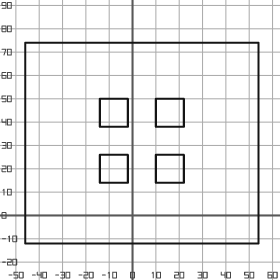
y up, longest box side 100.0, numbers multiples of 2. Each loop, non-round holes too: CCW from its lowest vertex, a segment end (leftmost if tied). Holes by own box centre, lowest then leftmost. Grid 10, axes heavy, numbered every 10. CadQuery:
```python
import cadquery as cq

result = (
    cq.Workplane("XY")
    .moveTo(-46.0, -12.0)
    .lineTo(54.0, -12.0)
    .lineTo(54.0, 74.0)
    .lineTo(-46.0, 74.0)
    .close()
    .moveTo(-14.0, 14.0)
    .lineTo(-2.0, 14.0)
    .lineTo(-2.0, 26.0)
    .lineTo(-14.0, 26.0)
    .close()
    .moveTo(10.0, 14.0)
    .lineTo(22.0, 14.0)
    .lineTo(22.0, 26.0)
    .lineTo(10.0, 26.0)
    .close()
    .moveTo(-14.0, 38.0)
    .lineTo(-2.0, 38.0)
    .lineTo(-2.0, 50.0)
    .lineTo(-14.0, 50.0)
    .close()
    .moveTo(10.0, 38.0)
    .lineTo(22.0, 38.0)
    .lineTo(22.0, 50.0)
    .lineTo(10.0, 50.0)
    .close()
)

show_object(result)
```